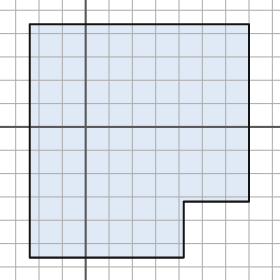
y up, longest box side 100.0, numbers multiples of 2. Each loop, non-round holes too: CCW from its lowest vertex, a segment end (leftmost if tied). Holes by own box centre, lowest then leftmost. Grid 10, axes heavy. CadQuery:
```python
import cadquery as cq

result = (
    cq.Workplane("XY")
    .moveTo(-24.0, -56.0)
    .lineTo(42.0, -56.0)
    .lineTo(42.0, -32.0)
    .lineTo(70.0, -32.0)
    .lineTo(70.0, 44.0)
    .lineTo(-24.0, 44.0)
    .close()
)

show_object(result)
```